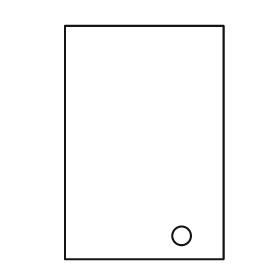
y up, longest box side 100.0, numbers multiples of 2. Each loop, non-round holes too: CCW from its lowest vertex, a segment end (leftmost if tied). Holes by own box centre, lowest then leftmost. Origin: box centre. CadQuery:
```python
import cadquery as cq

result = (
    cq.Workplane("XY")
    .moveTo(-34.0, -50.0)
    .lineTo(34.0, -50.0)
    .lineTo(34.0, 50.0)
    .lineTo(-34.0, 50.0)
    .close()
    .moveTo(16.0, -40.0)
    .circle(4.0)
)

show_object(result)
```